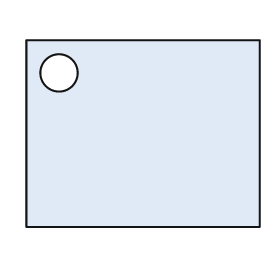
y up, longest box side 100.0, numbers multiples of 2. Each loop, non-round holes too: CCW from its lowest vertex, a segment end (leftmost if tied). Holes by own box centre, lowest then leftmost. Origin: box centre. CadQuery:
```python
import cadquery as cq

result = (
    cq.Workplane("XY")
    .moveTo(-50.0, -40.0)
    .lineTo(50.0, -40.0)
    .lineTo(50.0, 40.0)
    .lineTo(-50.0, 40.0)
    .close()
    .moveTo(-36.0, 26.0)
    .circle(8.0)
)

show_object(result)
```